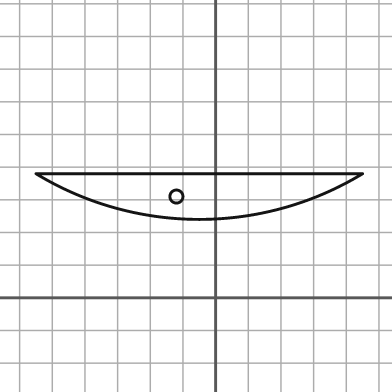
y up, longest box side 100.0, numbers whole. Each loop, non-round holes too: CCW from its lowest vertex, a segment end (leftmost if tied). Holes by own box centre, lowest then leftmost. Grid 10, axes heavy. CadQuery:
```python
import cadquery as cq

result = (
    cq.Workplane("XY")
    .moveTo(-55.0, 38.0)
    .threePointArc((-5.0, 24.0), (45.0, 38.0))
    .close()
    .moveTo(-12.0, 31.0)
    .circle(2.0)
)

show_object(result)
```